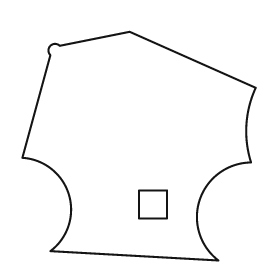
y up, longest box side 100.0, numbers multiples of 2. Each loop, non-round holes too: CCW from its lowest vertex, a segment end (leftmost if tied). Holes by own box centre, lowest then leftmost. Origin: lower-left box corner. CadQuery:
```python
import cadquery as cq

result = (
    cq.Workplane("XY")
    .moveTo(84.0, 0.0)
    .threePointArc((76.0, 26.0), (98.0, 42.0))
    .threePointArc((96.0, 58.0), (100.0, 74.0))
    .lineTo(46.0, 98.0)
    .lineTo(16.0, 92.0)
    .threePointArc((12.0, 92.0), (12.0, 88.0))
    .lineTo(0.0, 44.0)
    .threePointArc((20.0, 28.0), (12.0, 4.0))
    .close()
    .moveTo(50.0, 18.0)
    .lineTo(62.0, 18.0)
    .lineTo(62.0, 30.0)
    .lineTo(50.0, 30.0)
    .close()
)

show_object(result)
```